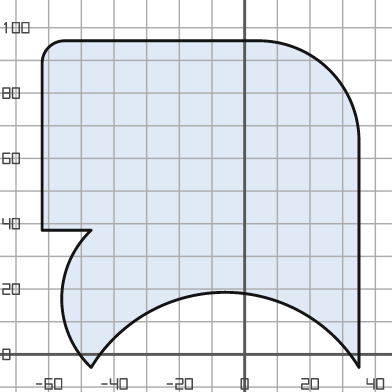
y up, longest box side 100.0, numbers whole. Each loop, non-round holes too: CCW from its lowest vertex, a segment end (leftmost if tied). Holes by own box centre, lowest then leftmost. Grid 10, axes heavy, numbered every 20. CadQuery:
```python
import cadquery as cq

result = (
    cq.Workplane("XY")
    .moveTo(-47.0, -4.0)
    .threePointArc((-6.0, 19.0), (35.0, -4.0))
    .lineTo(35.0, 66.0)
    .threePointArc((26.0, 87.0), (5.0, 96.0))
    .lineTo(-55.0, 96.0)
    .threePointArc((-60.0, 94.0), (-62.0, 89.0))
    .lineTo(-62.0, 38.0)
    .lineTo(-47.0, 38.0)
    .threePointArc((-56.0, 17.0), (-47.0, -4.0))
    .close()
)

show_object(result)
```